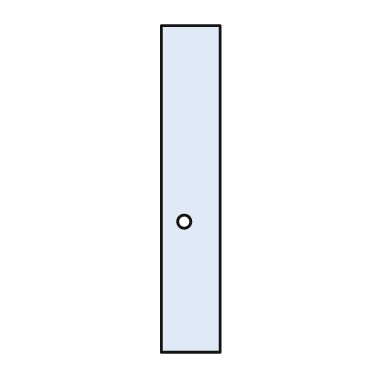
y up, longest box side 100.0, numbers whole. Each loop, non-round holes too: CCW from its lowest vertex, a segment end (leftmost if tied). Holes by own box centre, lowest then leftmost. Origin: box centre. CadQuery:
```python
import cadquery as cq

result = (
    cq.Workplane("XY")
    .moveTo(-9.0, -50.0)
    .lineTo(9.0, -50.0)
    .lineTo(9.0, 50.0)
    .lineTo(-9.0, 50.0)
    .close()
    .moveTo(-2.0, -10.0)
    .circle(2.0)
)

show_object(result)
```